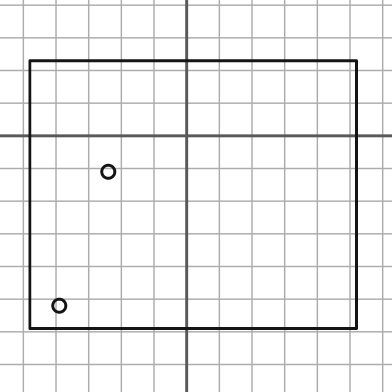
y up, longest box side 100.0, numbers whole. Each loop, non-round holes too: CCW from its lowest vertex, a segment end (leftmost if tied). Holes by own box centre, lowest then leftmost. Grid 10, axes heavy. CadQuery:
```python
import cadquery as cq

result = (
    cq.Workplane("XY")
    .moveTo(-48.0, -59.0)
    .lineTo(52.0, -59.0)
    .lineTo(52.0, 23.0)
    .lineTo(-48.0, 23.0)
    .close()
    .moveTo(-39.0, -52.0)
    .circle(2.0)
    .moveTo(-24.0, -11.0)
    .circle(2.0)
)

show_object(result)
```